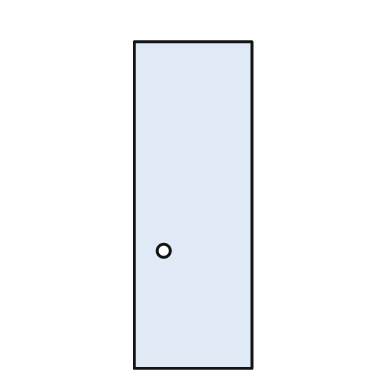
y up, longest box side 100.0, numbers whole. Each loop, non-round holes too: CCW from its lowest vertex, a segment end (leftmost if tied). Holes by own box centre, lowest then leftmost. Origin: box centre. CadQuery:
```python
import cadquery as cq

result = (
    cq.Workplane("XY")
    .moveTo(-18.0, -50.0)
    .lineTo(18.0, -50.0)
    .lineTo(18.0, 50.0)
    .lineTo(-18.0, 50.0)
    .close()
    .moveTo(-9.0, -14.0)
    .circle(2.0)
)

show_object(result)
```